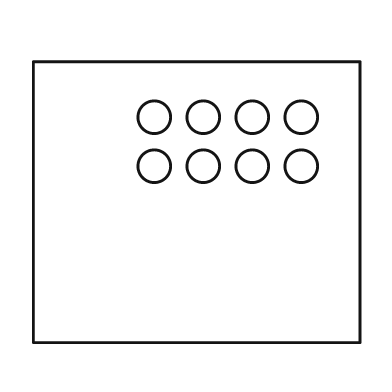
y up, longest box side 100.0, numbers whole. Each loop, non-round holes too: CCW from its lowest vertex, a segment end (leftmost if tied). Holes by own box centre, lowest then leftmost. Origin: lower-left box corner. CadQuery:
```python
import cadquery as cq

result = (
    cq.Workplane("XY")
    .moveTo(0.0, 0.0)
    .lineTo(100.0, 0.0)
    .lineTo(100.0, 86.0)
    .lineTo(0.0, 86.0)
    .close()
    .moveTo(37.0, 54.0)
    .circle(5.0)
    .moveTo(52.0, 54.0)
    .circle(5.0)
    .moveTo(67.0, 54.0)
    .circle(5.0)
    .moveTo(82.0, 54.0)
    .circle(5.0)
    .moveTo(37.0, 69.0)
    .circle(5.0)
    .moveTo(52.0, 69.0)
    .circle(5.0)
    .moveTo(67.0, 69.0)
    .circle(5.0)
    .moveTo(82.0, 69.0)
    .circle(5.0)
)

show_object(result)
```